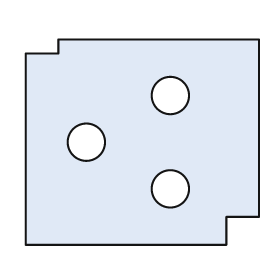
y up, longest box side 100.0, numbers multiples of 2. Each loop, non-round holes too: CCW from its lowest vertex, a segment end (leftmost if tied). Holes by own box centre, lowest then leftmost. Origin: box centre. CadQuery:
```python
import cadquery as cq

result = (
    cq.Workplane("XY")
    .moveTo(-50.0, -44.0)
    .lineTo(36.0, -44.0)
    .lineTo(36.0, -32.0)
    .lineTo(50.0, -32.0)
    .lineTo(50.0, 44.0)
    .lineTo(-36.0, 44.0)
    .lineTo(-36.0, 38.0)
    .lineTo(-50.0, 38.0)
    .close()
    .moveTo(12.0, -20.0)
    .circle(8.0)
    .moveTo(-24.0, 0.0)
    .circle(8.0)
    .moveTo(12.0, 20.0)
    .circle(8.0)
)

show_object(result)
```